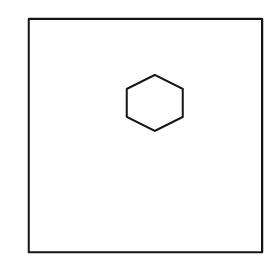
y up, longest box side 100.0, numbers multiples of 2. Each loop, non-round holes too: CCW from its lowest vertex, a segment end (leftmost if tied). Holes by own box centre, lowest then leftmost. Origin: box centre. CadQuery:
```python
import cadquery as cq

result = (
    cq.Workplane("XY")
    .moveTo(-50.0, -50.0)
    .lineTo(50.0, -50.0)
    .lineTo(50.0, 50.0)
    .lineTo(-50.0, 50.0)
    .close()
    .moveTo(4.0, 2.0)
    .lineTo(16.0, 8.0)
    .lineTo(16.0, 20.0)
    .lineTo(4.0, 26.0)
    .lineTo(-8.0, 20.0)
    .lineTo(-8.0, 8.0)
    .close()
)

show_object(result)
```